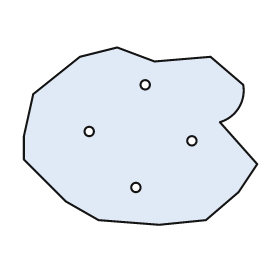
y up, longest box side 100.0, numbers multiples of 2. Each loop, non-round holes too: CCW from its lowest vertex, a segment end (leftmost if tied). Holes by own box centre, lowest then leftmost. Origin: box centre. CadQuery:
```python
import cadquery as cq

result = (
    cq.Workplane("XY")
    .moveTo(8.0, -38.0)
    .lineTo(28.0, -36.0)
    .lineTo(42.0, -24.0)
    .lineTo(50.0, -12.0)
    .lineTo(34.0, 6.0)
    .threePointArc((42.0, 12.0), (44.0, 22.0))
    .lineTo(30.0, 34.0)
    .lineTo(6.0, 32.0)
    .lineTo(-10.0, 38.0)
    .lineTo(-26.0, 34.0)
    .lineTo(-46.0, 18.0)
    .lineTo(-50.0, 0.0)
    .lineTo(-50.0, -10.0)
    .lineTo(-32.0, -28.0)
    .lineTo(-18.0, -36.0)
    .close()
    .moveTo(-2.0, -22.0)
    .circle(2.0)
    .moveTo(22.0, -2.0)
    .circle(2.0)
    .moveTo(-22.0, 2.0)
    .circle(2.0)
    .moveTo(2.0, 22.0)
    .circle(2.0)
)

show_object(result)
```